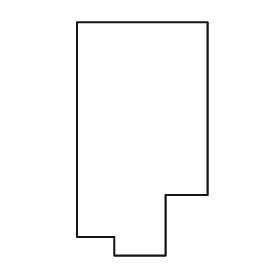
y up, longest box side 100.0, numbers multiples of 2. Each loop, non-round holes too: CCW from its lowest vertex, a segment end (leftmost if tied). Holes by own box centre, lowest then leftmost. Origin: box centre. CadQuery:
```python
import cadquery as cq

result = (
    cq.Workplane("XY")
    .moveTo(-12.0, -50.0)
    .lineTo(10.0, -50.0)
    .lineTo(10.0, -24.0)
    .lineTo(28.0, -24.0)
    .lineTo(28.0, 50.0)
    .lineTo(-28.0, 50.0)
    .lineTo(-28.0, -42.0)
    .lineTo(-12.0, -42.0)
    .close()
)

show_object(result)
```